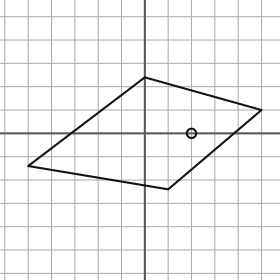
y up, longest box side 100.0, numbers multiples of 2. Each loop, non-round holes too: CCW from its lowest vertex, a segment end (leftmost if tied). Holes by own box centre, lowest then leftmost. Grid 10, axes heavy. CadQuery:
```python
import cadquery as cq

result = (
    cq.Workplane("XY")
    .moveTo(10.0, -24.0)
    .lineTo(50.0, 10.0)
    .lineTo(0.0, 24.0)
    .lineTo(-50.0, -14.0)
    .close()
    .moveTo(20.0, 0.0)
    .circle(2.0)
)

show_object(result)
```